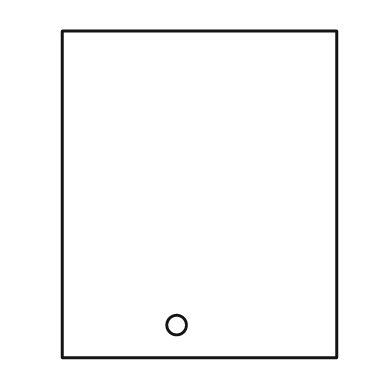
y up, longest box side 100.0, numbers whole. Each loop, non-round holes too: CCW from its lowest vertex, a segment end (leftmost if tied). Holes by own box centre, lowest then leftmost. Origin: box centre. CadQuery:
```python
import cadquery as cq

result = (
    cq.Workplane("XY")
    .moveTo(-42.0, -50.0)
    .lineTo(42.0, -50.0)
    .lineTo(42.0, 50.0)
    .lineTo(-42.0, 50.0)
    .close()
    .moveTo(-7.0, -40.0)
    .circle(3.0)
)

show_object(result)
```